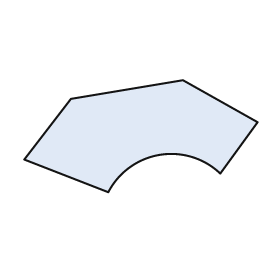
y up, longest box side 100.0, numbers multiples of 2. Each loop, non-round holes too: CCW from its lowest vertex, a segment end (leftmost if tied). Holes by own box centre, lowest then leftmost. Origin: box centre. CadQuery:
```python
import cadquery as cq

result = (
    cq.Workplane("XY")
    .moveTo(-14.0, -24.0)
    .threePointArc((8.0, -8.0), (34.0, -16.0))
    .lineTo(50.0, 6.0)
    .lineTo(18.0, 24.0)
    .lineTo(-30.0, 16.0)
    .lineTo(-50.0, -10.0)
    .close()
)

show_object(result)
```